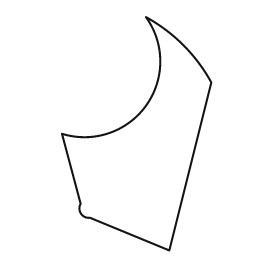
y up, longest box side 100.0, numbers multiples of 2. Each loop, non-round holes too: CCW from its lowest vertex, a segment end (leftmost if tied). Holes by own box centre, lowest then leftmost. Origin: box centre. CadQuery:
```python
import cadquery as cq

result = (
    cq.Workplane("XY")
    .moveTo(14.0, -50.0)
    .lineTo(32.0, 22.0)
    .threePointArc((20.0, 38.0), (4.0, 50.0))
    .threePointArc((4.0, 12.0), (-32.0, 0.0))
    .lineTo(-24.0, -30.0)
    .threePointArc((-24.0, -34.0), (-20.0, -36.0))
    .close()
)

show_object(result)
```